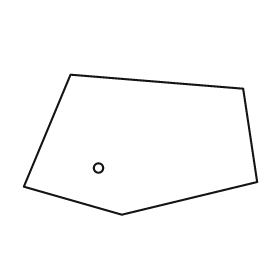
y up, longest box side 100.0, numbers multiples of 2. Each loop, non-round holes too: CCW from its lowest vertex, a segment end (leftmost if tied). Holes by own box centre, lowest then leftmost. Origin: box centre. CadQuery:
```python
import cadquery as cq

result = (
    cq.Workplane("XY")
    .moveTo(-8.0, -30.0)
    .lineTo(50.0, -16.0)
    .lineTo(44.0, 24.0)
    .lineTo(-30.0, 30.0)
    .lineTo(-50.0, -18.0)
    .close()
    .moveTo(-18.0, -10.0)
    .circle(2.0)
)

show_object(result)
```